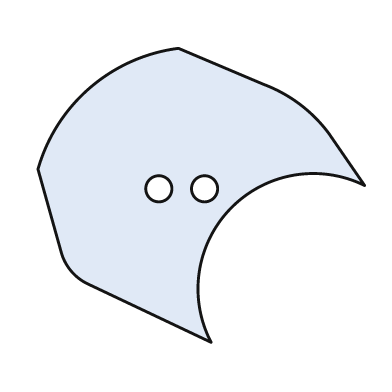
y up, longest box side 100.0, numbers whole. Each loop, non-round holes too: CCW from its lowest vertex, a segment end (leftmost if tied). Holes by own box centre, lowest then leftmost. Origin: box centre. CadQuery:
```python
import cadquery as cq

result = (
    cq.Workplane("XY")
    .moveTo(3.0, -45.0)
    .threePointArc((9.0, -4.0), (50.0, 3.0))
    .lineTo(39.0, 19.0)
    .threePointArc((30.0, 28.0), (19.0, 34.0))
    .lineTo(-7.0, 45.0)
    .threePointArc((-34.0, 33.0), (-50.0, 8.0))
    .lineTo(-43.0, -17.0)
    .threePointArc((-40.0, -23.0), (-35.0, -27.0))
    .close()
    .moveTo(-13.0, 2.0)
    .circle(4.0)
    .moveTo(1.0, 2.0)
    .circle(4.0)
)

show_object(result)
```